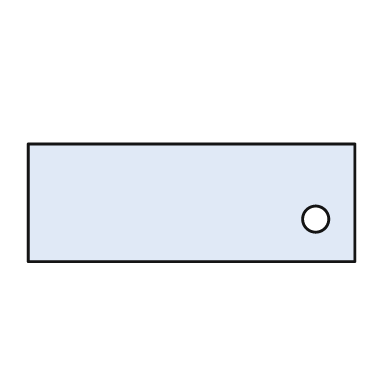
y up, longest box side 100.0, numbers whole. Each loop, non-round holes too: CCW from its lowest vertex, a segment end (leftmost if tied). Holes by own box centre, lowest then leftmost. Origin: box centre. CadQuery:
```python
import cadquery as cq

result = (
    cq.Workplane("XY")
    .moveTo(-50.0, -18.0)
    .lineTo(50.0, -18.0)
    .lineTo(50.0, 18.0)
    .lineTo(-50.0, 18.0)
    .close()
    .moveTo(38.0, -5.0)
    .circle(4.0)
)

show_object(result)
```